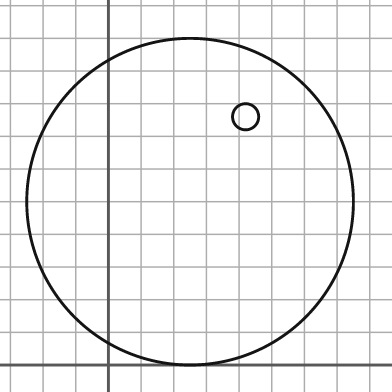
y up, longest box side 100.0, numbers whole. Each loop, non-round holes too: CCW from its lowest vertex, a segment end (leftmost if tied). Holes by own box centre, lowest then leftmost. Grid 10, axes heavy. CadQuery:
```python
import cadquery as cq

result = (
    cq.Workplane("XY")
    .moveTo(25.0, 50.0)
    .circle(50.0)
    .moveTo(42.0, 76.0)
    .circle(4.0)
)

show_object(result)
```